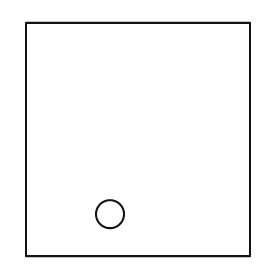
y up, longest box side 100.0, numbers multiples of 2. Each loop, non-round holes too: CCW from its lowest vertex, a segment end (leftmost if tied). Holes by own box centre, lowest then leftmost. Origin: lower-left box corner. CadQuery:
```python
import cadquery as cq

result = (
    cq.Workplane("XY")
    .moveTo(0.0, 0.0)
    .lineTo(96.0, 0.0)
    .lineTo(96.0, 100.0)
    .lineTo(0.0, 100.0)
    .close()
    .moveTo(36.0, 18.0)
    .circle(6.0)
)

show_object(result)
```